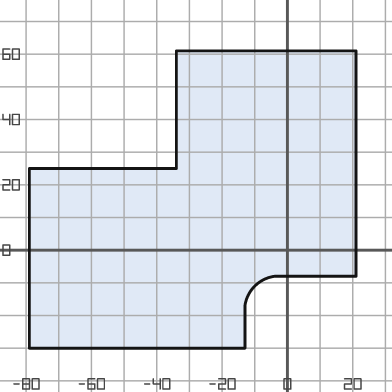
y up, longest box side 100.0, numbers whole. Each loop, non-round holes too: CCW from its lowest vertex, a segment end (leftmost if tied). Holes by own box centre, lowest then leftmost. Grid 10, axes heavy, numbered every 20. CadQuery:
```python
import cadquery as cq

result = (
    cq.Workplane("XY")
    .moveTo(-79.0, -30.0)
    .lineTo(-13.0, -30.0)
    .lineTo(-13.0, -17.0)
    .threePointArc((-10.0, -11.0), (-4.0, -8.0))
    .lineTo(21.0, -8.0)
    .lineTo(21.0, 61.0)
    .lineTo(-34.0, 61.0)
    .lineTo(-34.0, 25.0)
    .lineTo(-79.0, 25.0)
    .close()
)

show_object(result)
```